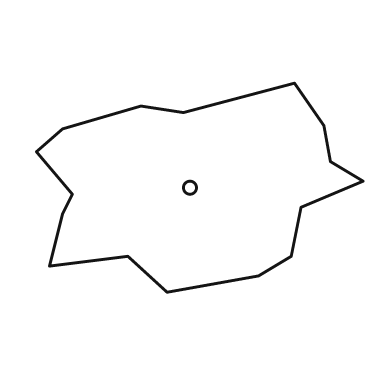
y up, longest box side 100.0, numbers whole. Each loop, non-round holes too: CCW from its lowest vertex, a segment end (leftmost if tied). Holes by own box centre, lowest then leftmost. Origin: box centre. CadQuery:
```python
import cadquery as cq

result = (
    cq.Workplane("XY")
    .moveTo(-10.0, -32.0)
    .lineTo(18.0, -27.0)
    .lineTo(28.0, -21.0)
    .lineTo(31.0, -6.0)
    .lineTo(50.0, 2.0)
    .lineTo(40.0, 8.0)
    .lineTo(38.0, 19.0)
    .lineTo(29.0, 32.0)
    .lineTo(-5.0, 23.0)
    .lineTo(-18.0, 25.0)
    .lineTo(-42.0, 18.0)
    .lineTo(-50.0, 11.0)
    .lineTo(-39.0, -2.0)
    .lineTo(-42.0, -8.0)
    .lineTo(-46.0, -24.0)
    .lineTo(-22.0, -21.0)
    .close()
    .moveTo(-3.0, 0.0)
    .circle(2.0)
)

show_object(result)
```